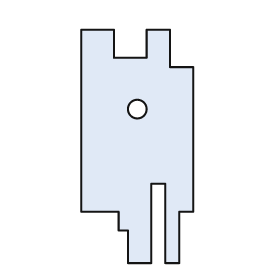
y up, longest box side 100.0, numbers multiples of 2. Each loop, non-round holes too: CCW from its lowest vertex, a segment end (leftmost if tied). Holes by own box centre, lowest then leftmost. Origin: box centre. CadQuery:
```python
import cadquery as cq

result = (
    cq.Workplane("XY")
    .moveTo(-4.0, -50.0)
    .lineTo(6.0, -50.0)
    .lineTo(6.0, -16.0)
    .lineTo(12.0, -16.0)
    .lineTo(12.0, -50.0)
    .lineTo(18.0, -50.0)
    .lineTo(18.0, -28.0)
    .lineTo(24.0, -28.0)
    .lineTo(24.0, 34.0)
    .lineTo(14.0, 34.0)
    .lineTo(14.0, 50.0)
    .lineTo(4.0, 50.0)
    .lineTo(4.0, 38.0)
    .lineTo(-10.0, 38.0)
    .lineTo(-10.0, 50.0)
    .lineTo(-24.0, 50.0)
    .lineTo(-24.0, -28.0)
    .lineTo(-8.0, -28.0)
    .lineTo(-8.0, -36.0)
    .lineTo(-4.0, -36.0)
    .close()
    .moveTo(0.0, 16.0)
    .circle(4.0)
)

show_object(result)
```